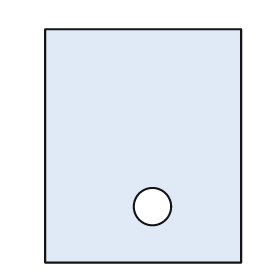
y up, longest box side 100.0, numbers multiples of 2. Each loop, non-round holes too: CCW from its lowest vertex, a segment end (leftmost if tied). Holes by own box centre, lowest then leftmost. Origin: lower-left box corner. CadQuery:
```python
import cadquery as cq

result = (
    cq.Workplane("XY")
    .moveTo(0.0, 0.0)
    .lineTo(84.0, 0.0)
    .lineTo(84.0, 100.0)
    .lineTo(0.0, 100.0)
    .close()
    .moveTo(46.0, 24.0)
    .circle(8.0)
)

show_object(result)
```